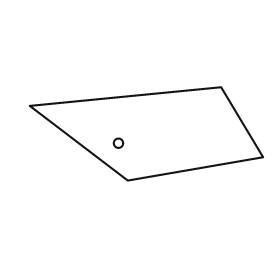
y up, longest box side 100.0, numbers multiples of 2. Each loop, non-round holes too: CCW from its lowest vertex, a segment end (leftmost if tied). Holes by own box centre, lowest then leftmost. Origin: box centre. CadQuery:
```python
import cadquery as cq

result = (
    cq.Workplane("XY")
    .moveTo(-8.0, -20.0)
    .lineTo(50.0, -10.0)
    .lineTo(32.0, 20.0)
    .lineTo(-50.0, 12.0)
    .close()
    .moveTo(-12.0, -4.0)
    .circle(2.0)
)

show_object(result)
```